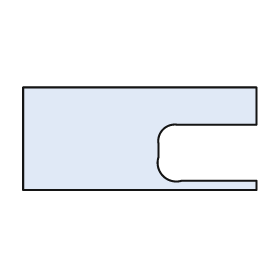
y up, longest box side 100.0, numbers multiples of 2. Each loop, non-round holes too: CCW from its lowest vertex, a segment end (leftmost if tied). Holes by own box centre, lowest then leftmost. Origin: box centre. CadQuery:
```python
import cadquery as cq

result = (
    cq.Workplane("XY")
    .moveTo(-50.0, -22.0)
    .lineTo(50.0, -22.0)
    .lineTo(50.0, -18.0)
    .lineTo(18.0, -18.0)
    .threePointArc((10.0, -16.0), (8.0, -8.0))
    .lineTo(8.0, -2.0)
    .threePointArc((10.0, 4.0), (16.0, 6.0))
    .lineTo(50.0, 6.0)
    .lineTo(50.0, 22.0)
    .lineTo(-50.0, 22.0)
    .close()
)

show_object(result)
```